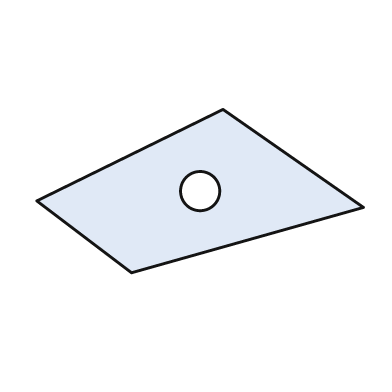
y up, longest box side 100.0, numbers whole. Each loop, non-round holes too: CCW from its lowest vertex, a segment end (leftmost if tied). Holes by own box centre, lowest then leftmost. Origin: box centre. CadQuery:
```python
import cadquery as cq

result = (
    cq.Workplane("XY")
    .moveTo(-21.0, -25.0)
    .lineTo(50.0, -5.0)
    .lineTo(7.0, 25.0)
    .lineTo(-50.0, -3.0)
    .close()
    .moveTo(0.0, 0.0)
    .circle(6.0)
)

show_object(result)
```